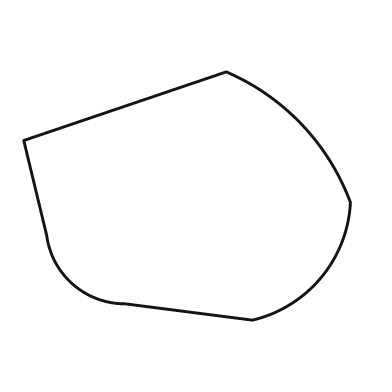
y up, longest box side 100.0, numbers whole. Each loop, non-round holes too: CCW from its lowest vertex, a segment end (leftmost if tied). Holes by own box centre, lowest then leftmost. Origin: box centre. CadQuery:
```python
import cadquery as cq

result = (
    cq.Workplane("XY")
    .moveTo(20.0, -38.0)
    .threePointArc((41.0, -25.0), (50.0, -2.0))
    .threePointArc((35.0, 22.0), (12.0, 38.0))
    .lineTo(-50.0, 17.0)
    .lineTo(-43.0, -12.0)
    .threePointArc((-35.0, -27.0), (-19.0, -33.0))
    .close()
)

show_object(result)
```